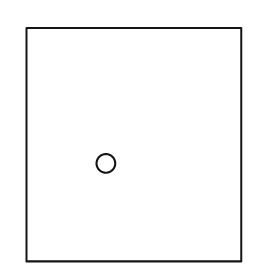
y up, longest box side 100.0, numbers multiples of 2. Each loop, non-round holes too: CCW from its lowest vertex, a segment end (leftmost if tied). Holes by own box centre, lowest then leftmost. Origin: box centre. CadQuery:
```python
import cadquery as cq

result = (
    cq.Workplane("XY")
    .moveTo(-46.0, -50.0)
    .lineTo(46.0, -50.0)
    .lineTo(46.0, 50.0)
    .lineTo(-46.0, 50.0)
    .close()
    .moveTo(-12.0, -8.0)
    .circle(4.0)
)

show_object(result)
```